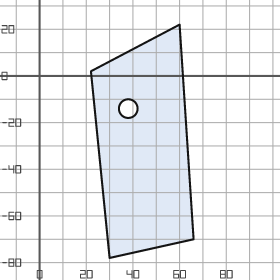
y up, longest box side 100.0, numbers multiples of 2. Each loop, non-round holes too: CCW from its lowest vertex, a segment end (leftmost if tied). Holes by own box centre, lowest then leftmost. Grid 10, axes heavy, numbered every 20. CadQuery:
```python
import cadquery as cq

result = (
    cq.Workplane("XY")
    .moveTo(30.0, -78.0)
    .lineTo(66.0, -70.0)
    .lineTo(60.0, 22.0)
    .lineTo(22.0, 2.0)
    .close()
    .moveTo(38.0, -14.0)
    .circle(4.0)
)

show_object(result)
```